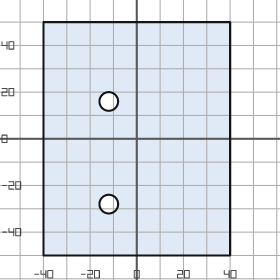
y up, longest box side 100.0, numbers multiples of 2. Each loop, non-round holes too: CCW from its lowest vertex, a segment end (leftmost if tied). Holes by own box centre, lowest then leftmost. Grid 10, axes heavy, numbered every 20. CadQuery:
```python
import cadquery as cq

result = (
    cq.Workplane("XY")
    .moveTo(-40.0, -50.0)
    .lineTo(40.0, -50.0)
    .lineTo(40.0, 50.0)
    .lineTo(-40.0, 50.0)
    .close()
    .moveTo(-12.0, -28.0)
    .circle(4.0)
    .moveTo(-12.0, 16.0)
    .circle(4.0)
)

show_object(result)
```